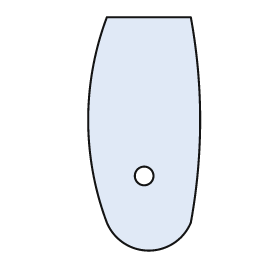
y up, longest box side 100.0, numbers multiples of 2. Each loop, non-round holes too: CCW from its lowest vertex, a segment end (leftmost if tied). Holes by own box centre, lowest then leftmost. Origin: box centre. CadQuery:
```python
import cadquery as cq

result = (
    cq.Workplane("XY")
    .moveTo(-16.0, -38.0)
    .threePointArc((2.0, -50.0), (20.0, -38.0))
    .threePointArc((24.0, 6.0), (20.0, 50.0))
    .lineTo(-16.0, 50.0)
    .threePointArc((-24.0, 6.0), (-16.0, -38.0))
    .close()
    .moveTo(0.0, -18.0)
    .circle(4.0)
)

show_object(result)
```